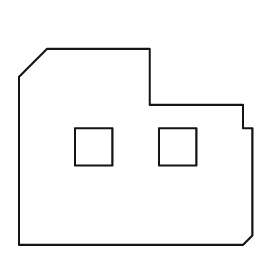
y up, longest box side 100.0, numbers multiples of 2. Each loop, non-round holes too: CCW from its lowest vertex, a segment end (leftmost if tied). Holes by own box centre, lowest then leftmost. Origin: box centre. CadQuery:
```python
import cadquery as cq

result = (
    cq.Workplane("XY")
    .moveTo(-50.0, -42.0)
    .lineTo(46.0, -42.0)
    .lineTo(50.0, -38.0)
    .lineTo(50.0, 8.0)
    .lineTo(46.0, 8.0)
    .lineTo(46.0, 18.0)
    .lineTo(6.0, 18.0)
    .lineTo(6.0, 42.0)
    .lineTo(-38.0, 42.0)
    .lineTo(-50.0, 30.0)
    .close()
    .moveTo(-26.0, -8.0)
    .lineTo(-10.0, -8.0)
    .lineTo(-10.0, 8.0)
    .lineTo(-26.0, 8.0)
    .close()
    .moveTo(10.0, -8.0)
    .lineTo(26.0, -8.0)
    .lineTo(26.0, 8.0)
    .lineTo(10.0, 8.0)
    .close()
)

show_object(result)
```